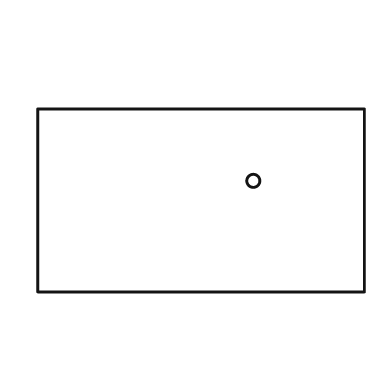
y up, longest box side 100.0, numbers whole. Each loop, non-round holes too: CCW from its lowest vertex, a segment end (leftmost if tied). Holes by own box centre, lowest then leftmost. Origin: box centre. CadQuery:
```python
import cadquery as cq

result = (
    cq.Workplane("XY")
    .moveTo(-50.0, -28.0)
    .lineTo(50.0, -28.0)
    .lineTo(50.0, 28.0)
    .lineTo(-50.0, 28.0)
    .close()
    .moveTo(16.0, 6.0)
    .circle(2.0)
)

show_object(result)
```